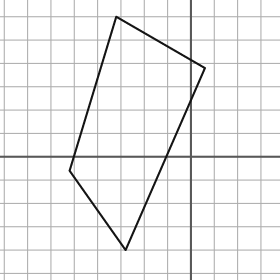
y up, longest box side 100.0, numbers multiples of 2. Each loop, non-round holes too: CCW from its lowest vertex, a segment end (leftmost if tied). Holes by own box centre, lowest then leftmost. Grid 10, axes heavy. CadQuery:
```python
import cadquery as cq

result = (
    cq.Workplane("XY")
    .moveTo(-28.0, -40.0)
    .lineTo(6.0, 38.0)
    .lineTo(-32.0, 60.0)
    .lineTo(-52.0, -6.0)
    .close()
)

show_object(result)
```